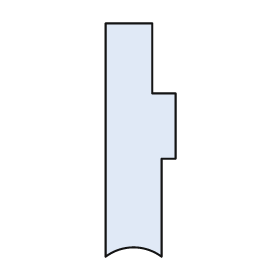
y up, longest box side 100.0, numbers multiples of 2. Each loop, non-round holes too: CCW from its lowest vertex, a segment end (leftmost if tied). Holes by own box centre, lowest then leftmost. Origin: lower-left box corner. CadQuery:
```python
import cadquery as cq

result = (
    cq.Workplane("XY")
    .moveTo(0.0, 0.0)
    .threePointArc((12.0, 4.0), (24.0, 0.0))
    .lineTo(24.0, 42.0)
    .lineTo(30.0, 42.0)
    .lineTo(30.0, 70.0)
    .lineTo(20.0, 70.0)
    .lineTo(20.0, 100.0)
    .lineTo(0.0, 100.0)
    .close()
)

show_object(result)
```